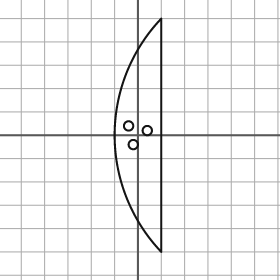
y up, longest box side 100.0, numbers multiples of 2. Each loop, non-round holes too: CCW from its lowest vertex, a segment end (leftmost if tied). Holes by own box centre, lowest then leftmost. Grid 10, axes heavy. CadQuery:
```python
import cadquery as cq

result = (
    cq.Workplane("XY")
    .moveTo(10.0, -50.0)
    .lineTo(10.0, 50.0)
    .threePointArc((-10.0, 0.0), (10.0, -50.0))
    .close()
    .moveTo(-2.0, -4.0)
    .circle(2.0)
    .moveTo(4.0, 2.0)
    .circle(2.0)
    .moveTo(-4.0, 4.0)
    .circle(2.0)
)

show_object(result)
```